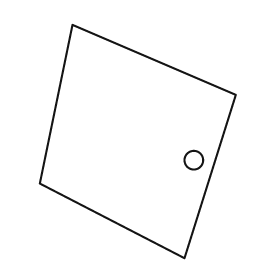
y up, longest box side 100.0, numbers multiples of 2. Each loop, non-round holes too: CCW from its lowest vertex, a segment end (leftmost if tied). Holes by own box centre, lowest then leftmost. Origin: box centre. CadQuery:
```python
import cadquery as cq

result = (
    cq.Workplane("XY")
    .moveTo(20.0, -50.0)
    .lineTo(42.0, 20.0)
    .lineTo(-28.0, 50.0)
    .lineTo(-42.0, -18.0)
    .close()
    .moveTo(24.0, -8.0)
    .circle(4.0)
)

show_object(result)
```